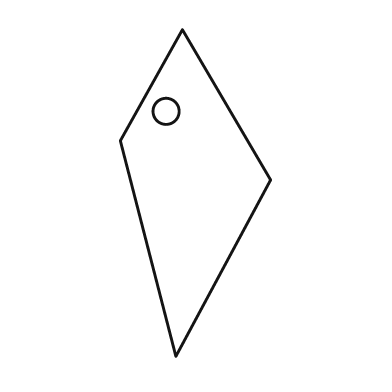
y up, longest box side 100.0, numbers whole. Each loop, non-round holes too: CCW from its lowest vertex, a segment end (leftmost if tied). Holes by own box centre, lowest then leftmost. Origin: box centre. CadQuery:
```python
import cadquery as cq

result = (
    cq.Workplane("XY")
    .moveTo(-6.0, -50.0)
    .lineTo(23.0, 4.0)
    .lineTo(-4.0, 50.0)
    .lineTo(-23.0, 16.0)
    .close()
    .moveTo(-9.0, 25.0)
    .circle(4.0)
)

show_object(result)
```